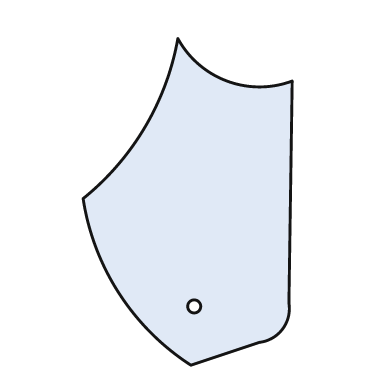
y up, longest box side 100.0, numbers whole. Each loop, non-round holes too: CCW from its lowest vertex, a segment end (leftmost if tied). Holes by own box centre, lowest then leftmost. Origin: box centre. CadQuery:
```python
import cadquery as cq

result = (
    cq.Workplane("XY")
    .moveTo(1.0, -50.0)
    .lineTo(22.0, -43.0)
    .threePointArc((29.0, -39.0), (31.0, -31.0))
    .lineTo(32.0, 37.0)
    .threePointArc((12.0, 37.0), (-3.0, 50.0))
    .threePointArc((-13.0, 23.0), (-32.0, 1.0))
    .threePointArc((-21.0, -28.0), (1.0, -50.0))
    .close()
    .moveTo(2.0, -32.0)
    .circle(2.0)
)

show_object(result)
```